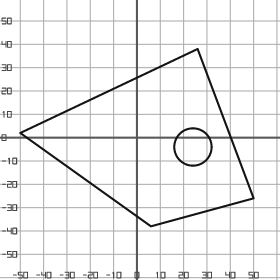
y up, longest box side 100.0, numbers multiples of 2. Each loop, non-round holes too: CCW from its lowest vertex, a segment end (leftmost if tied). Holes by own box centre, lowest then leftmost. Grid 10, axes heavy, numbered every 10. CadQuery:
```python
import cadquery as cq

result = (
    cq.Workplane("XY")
    .moveTo(6.0, -38.0)
    .lineTo(50.0, -26.0)
    .lineTo(26.0, 38.0)
    .lineTo(-50.0, 2.0)
    .close()
    .moveTo(24.0, -4.0)
    .circle(8.0)
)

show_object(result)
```